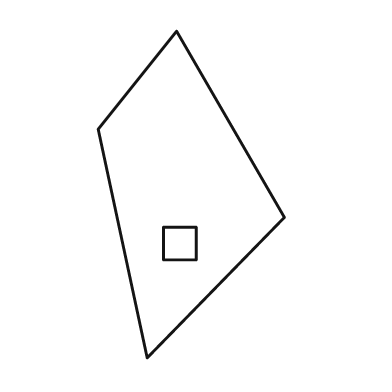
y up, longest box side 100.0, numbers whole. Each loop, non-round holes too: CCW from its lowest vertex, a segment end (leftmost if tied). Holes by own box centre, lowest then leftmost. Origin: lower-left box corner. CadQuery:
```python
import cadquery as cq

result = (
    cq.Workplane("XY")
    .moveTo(15.0, 0.0)
    .lineTo(57.0, 43.0)
    .lineTo(24.0, 100.0)
    .lineTo(0.0, 70.0)
    .close()
    .moveTo(20.0, 30.0)
    .lineTo(30.0, 30.0)
    .lineTo(30.0, 40.0)
    .lineTo(20.0, 40.0)
    .close()
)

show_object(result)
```